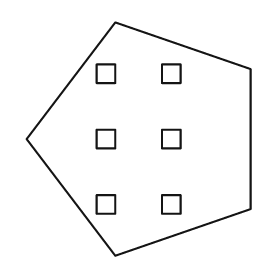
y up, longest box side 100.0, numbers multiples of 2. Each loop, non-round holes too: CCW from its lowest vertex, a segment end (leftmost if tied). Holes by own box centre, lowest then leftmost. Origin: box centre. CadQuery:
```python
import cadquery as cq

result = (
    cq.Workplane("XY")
    .moveTo(-10.0, -50.0)
    .lineTo(48.0, -30.0)
    .lineTo(48.0, 30.0)
    .lineTo(-10.0, 50.0)
    .lineTo(-48.0, 0.0)
    .close()
    .moveTo(-18.0, -32.0)
    .lineTo(-10.0, -32.0)
    .lineTo(-10.0, -24.0)
    .lineTo(-18.0, -24.0)
    .close()
    .moveTo(10.0, -32.0)
    .lineTo(18.0, -32.0)
    .lineTo(18.0, -24.0)
    .lineTo(10.0, -24.0)
    .close()
    .moveTo(-18.0, -4.0)
    .lineTo(-10.0, -4.0)
    .lineTo(-10.0, 4.0)
    .lineTo(-18.0, 4.0)
    .close()
    .moveTo(10.0, -4.0)
    .lineTo(18.0, -4.0)
    .lineTo(18.0, 4.0)
    .lineTo(10.0, 4.0)
    .close()
    .moveTo(-18.0, 24.0)
    .lineTo(-10.0, 24.0)
    .lineTo(-10.0, 32.0)
    .lineTo(-18.0, 32.0)
    .close()
    .moveTo(10.0, 24.0)
    .lineTo(18.0, 24.0)
    .lineTo(18.0, 32.0)
    .lineTo(10.0, 32.0)
    .close()
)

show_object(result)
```